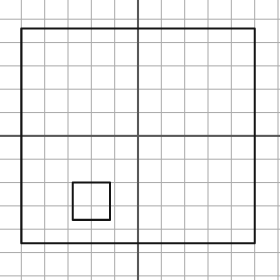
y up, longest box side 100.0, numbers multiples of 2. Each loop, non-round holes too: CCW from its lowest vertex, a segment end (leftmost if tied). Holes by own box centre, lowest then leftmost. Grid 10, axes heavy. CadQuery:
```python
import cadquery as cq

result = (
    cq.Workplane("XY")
    .moveTo(-50.0, -46.0)
    .lineTo(50.0, -46.0)
    .lineTo(50.0, 46.0)
    .lineTo(-50.0, 46.0)
    .close()
    .moveTo(-28.0, -36.0)
    .lineTo(-12.0, -36.0)
    .lineTo(-12.0, -20.0)
    .lineTo(-28.0, -20.0)
    .close()
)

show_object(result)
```